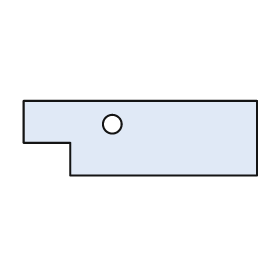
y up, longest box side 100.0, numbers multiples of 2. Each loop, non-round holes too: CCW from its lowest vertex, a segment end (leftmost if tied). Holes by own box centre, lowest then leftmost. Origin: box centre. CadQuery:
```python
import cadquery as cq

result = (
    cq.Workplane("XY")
    .moveTo(-30.0, -16.0)
    .lineTo(50.0, -16.0)
    .lineTo(50.0, 16.0)
    .lineTo(-50.0, 16.0)
    .lineTo(-50.0, -2.0)
    .lineTo(-30.0, -2.0)
    .close()
    .moveTo(-12.0, 6.0)
    .circle(4.0)
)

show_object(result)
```